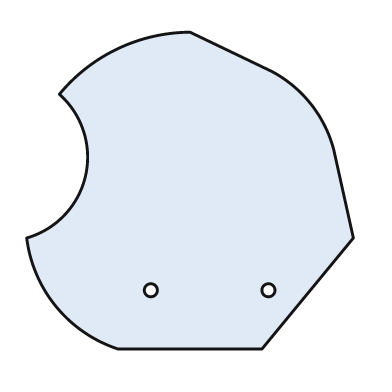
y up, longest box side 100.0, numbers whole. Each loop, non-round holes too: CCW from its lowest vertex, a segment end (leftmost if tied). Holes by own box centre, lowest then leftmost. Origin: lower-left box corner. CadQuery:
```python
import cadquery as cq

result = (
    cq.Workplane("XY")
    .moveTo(28.0, 0.0)
    .lineTo(72.0, 0.0)
    .lineTo(100.0, 34.0)
    .lineTo(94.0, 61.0)
    .threePointArc((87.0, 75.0), (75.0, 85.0))
    .lineTo(50.0, 97.0)
    .threePointArc((28.0, 92.0), (10.0, 78.0))
    .threePointArc((18.0, 53.0), (0.0, 34.0))
    .threePointArc((9.0, 13.0), (28.0, 0.0))
    .close()
    .moveTo(38.0, 18.0)
    .circle(2.0)
    .moveTo(74.0, 18.0)
    .circle(2.0)
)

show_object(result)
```